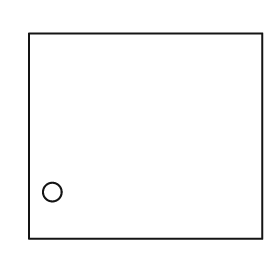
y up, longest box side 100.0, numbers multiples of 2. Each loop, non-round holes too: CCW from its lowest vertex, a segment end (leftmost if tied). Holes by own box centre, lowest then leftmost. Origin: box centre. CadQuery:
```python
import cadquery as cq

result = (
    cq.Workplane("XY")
    .moveTo(-50.0, -44.0)
    .lineTo(50.0, -44.0)
    .lineTo(50.0, 44.0)
    .lineTo(-50.0, 44.0)
    .close()
    .moveTo(-40.0, -24.0)
    .circle(4.0)
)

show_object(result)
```